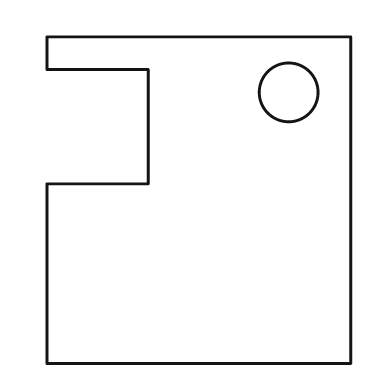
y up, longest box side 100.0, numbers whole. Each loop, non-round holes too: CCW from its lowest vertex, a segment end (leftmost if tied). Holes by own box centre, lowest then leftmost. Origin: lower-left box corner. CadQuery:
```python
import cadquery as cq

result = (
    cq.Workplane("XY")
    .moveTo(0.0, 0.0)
    .lineTo(93.0, 0.0)
    .lineTo(93.0, 100.0)
    .lineTo(0.0, 100.0)
    .lineTo(0.0, 90.0)
    .lineTo(31.0, 90.0)
    .lineTo(31.0, 55.0)
    .lineTo(0.0, 55.0)
    .close()
    .moveTo(74.0, 83.0)
    .circle(9.0)
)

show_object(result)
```